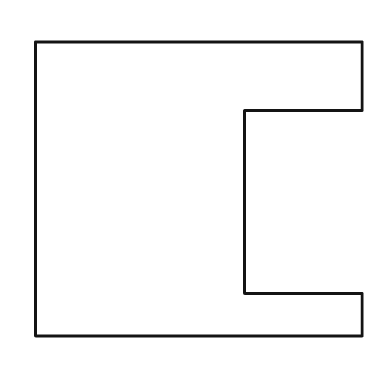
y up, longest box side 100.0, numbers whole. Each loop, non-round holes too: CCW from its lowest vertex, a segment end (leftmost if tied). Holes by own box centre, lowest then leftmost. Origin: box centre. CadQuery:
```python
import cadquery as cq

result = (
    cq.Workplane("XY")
    .moveTo(-50.0, -45.0)
    .lineTo(50.0, -45.0)
    .lineTo(50.0, -32.0)
    .lineTo(14.0, -32.0)
    .lineTo(14.0, 24.0)
    .lineTo(50.0, 24.0)
    .lineTo(50.0, 45.0)
    .lineTo(-50.0, 45.0)
    .close()
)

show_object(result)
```